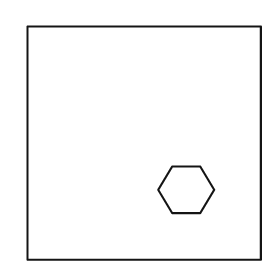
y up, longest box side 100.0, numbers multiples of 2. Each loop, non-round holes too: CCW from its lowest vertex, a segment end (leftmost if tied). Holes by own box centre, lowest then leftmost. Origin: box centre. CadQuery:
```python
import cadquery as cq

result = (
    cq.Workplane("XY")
    .moveTo(-50.0, -50.0)
    .lineTo(50.0, -50.0)
    .lineTo(50.0, 50.0)
    .lineTo(-50.0, 50.0)
    .close()
    .moveTo(12.0, -30.0)
    .lineTo(24.0, -30.0)
    .lineTo(30.0, -20.0)
    .lineTo(24.0, -10.0)
    .lineTo(12.0, -10.0)
    .lineTo(6.0, -20.0)
    .close()
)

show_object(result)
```